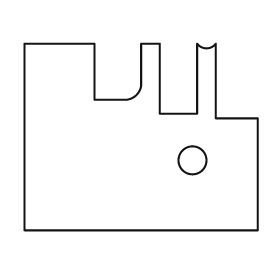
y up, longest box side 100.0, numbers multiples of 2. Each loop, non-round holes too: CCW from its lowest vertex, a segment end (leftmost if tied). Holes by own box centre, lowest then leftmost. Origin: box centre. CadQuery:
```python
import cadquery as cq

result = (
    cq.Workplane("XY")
    .moveTo(-50.0, -40.0)
    .lineTo(50.0, -40.0)
    .lineTo(50.0, 8.0)
    .lineTo(32.0, 8.0)
    .lineTo(32.0, 40.0)
    .threePointArc((28.0, 38.0), (24.0, 40.0))
    .lineTo(24.0, 10.0)
    .lineTo(8.0, 10.0)
    .lineTo(8.0, 40.0)
    .lineTo(0.0, 40.0)
    .lineTo(0.0, 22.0)
    .threePointArc((-2.0, 18.0), (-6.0, 16.0))
    .lineTo(-20.0, 16.0)
    .lineTo(-20.0, 40.0)
    .lineTo(-50.0, 40.0)
    .close()
    .moveTo(22.0, -10.0)
    .circle(6.0)
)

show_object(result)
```